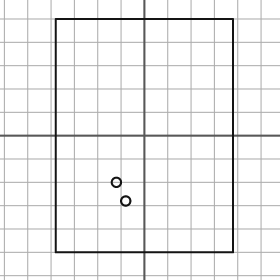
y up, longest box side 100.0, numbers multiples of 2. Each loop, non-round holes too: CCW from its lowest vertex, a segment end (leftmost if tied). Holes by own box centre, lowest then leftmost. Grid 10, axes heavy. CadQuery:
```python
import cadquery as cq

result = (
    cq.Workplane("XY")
    .moveTo(-38.0, -50.0)
    .lineTo(38.0, -50.0)
    .lineTo(38.0, 50.0)
    .lineTo(-38.0, 50.0)
    .close()
    .moveTo(-8.0, -28.0)
    .circle(2.0)
    .moveTo(-12.0, -20.0)
    .circle(2.0)
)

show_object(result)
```